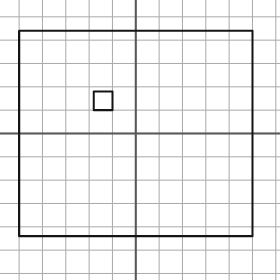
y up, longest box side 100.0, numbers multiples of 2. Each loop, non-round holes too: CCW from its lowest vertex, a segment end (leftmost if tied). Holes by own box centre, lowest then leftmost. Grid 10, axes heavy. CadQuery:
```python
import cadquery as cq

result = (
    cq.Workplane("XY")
    .moveTo(-50.0, -44.0)
    .lineTo(50.0, -44.0)
    .lineTo(50.0, 44.0)
    .lineTo(-50.0, 44.0)
    .close()
    .moveTo(-18.0, 10.0)
    .lineTo(-10.0, 10.0)
    .lineTo(-10.0, 18.0)
    .lineTo(-18.0, 18.0)
    .close()
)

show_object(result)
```